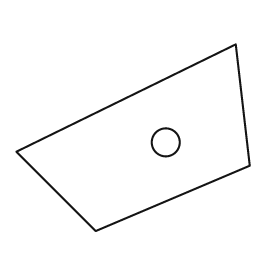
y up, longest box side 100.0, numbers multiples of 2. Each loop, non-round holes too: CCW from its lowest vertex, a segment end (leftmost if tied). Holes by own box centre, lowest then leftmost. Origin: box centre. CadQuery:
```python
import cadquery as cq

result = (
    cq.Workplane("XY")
    .moveTo(-16.0, -40.0)
    .lineTo(50.0, -12.0)
    .lineTo(44.0, 40.0)
    .lineTo(-50.0, -6.0)
    .close()
    .moveTo(14.0, -2.0)
    .circle(6.0)
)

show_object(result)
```